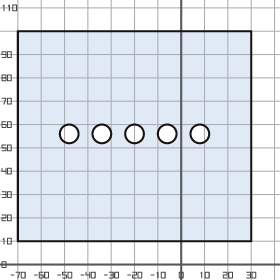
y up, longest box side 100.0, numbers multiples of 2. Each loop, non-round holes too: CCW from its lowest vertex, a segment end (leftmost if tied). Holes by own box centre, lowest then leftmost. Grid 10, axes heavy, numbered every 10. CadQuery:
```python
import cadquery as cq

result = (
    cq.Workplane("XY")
    .moveTo(-70.0, 10.0)
    .lineTo(30.0, 10.0)
    .lineTo(30.0, 100.0)
    .lineTo(-70.0, 100.0)
    .close()
    .moveTo(-48.0, 56.0)
    .circle(4.0)
    .moveTo(-34.0, 56.0)
    .circle(4.0)
    .moveTo(-20.0, 56.0)
    .circle(4.0)
    .moveTo(-6.0, 56.0)
    .circle(4.0)
    .moveTo(8.0, 56.0)
    .circle(4.0)
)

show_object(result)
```